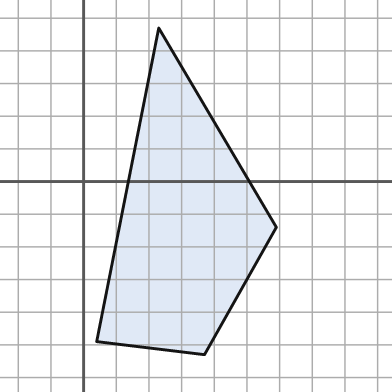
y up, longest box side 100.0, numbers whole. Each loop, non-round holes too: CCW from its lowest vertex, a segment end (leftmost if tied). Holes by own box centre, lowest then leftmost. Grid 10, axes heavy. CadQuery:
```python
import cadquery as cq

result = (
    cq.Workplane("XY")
    .moveTo(37.0, -53.0)
    .lineTo(59.0, -14.0)
    .lineTo(23.0, 47.0)
    .lineTo(4.0, -49.0)
    .close()
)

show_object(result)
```